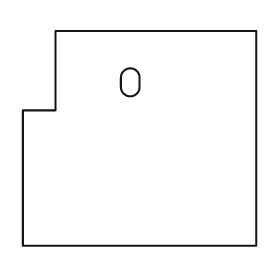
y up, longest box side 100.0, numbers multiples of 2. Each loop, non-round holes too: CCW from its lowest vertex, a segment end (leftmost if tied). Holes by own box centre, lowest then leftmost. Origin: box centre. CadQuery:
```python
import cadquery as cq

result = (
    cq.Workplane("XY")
    .moveTo(-50.0, -46.0)
    .lineTo(50.0, -46.0)
    .lineTo(50.0, 46.0)
    .lineTo(-36.0, 46.0)
    .lineTo(-36.0, 12.0)
    .lineTo(-50.0, 12.0)
    .close()
    .moveTo(-8.0, 22.0)
    .threePointArc((-4.0, 18.0), (0.0, 22.0))
    .lineTo(0.0, 26.0)
    .threePointArc((-4.0, 30.0), (-8.0, 26.0))
    .close()
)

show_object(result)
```